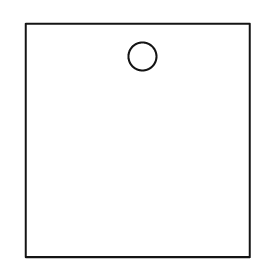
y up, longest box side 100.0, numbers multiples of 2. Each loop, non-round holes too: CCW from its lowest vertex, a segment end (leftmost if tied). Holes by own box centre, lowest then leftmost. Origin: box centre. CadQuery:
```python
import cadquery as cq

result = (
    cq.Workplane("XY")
    .moveTo(-48.0, -50.0)
    .lineTo(48.0, -50.0)
    .lineTo(48.0, 50.0)
    .lineTo(-48.0, 50.0)
    .close()
    .moveTo(2.0, 36.0)
    .circle(6.0)
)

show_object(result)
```